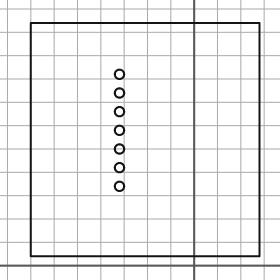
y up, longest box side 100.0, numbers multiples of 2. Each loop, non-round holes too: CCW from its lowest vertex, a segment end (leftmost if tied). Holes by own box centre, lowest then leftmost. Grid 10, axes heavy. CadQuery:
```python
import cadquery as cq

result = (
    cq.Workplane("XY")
    .moveTo(-70.0, 4.0)
    .lineTo(28.0, 4.0)
    .lineTo(28.0, 104.0)
    .lineTo(-70.0, 104.0)
    .close()
    .moveTo(-32.0, 34.0)
    .circle(2.0)
    .moveTo(-32.0, 42.0)
    .circle(2.0)
    .moveTo(-32.0, 50.0)
    .circle(2.0)
    .moveTo(-32.0, 58.0)
    .circle(2.0)
    .moveTo(-32.0, 66.0)
    .circle(2.0)
    .moveTo(-32.0, 74.0)
    .circle(2.0)
    .moveTo(-32.0, 82.0)
    .circle(2.0)
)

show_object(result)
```